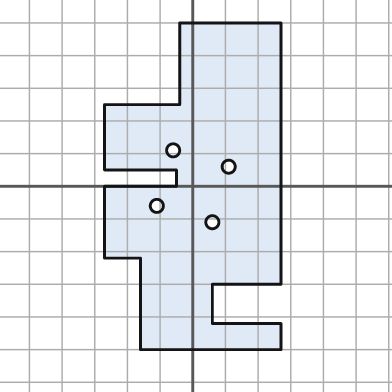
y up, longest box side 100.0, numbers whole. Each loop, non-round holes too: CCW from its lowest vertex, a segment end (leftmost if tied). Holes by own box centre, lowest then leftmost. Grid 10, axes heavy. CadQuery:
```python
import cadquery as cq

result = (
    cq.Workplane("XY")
    .moveTo(-16.0, -50.0)
    .lineTo(27.0, -50.0)
    .lineTo(27.0, -42.0)
    .lineTo(6.0, -42.0)
    .lineTo(6.0, -30.0)
    .lineTo(27.0, -30.0)
    .lineTo(27.0, 50.0)
    .lineTo(-4.0, 50.0)
    .lineTo(-4.0, 25.0)
    .lineTo(-27.0, 25.0)
    .lineTo(-27.0, 5.0)
    .lineTo(-5.0, 5.0)
    .lineTo(-5.0, 0.0)
    .lineTo(-27.0, 0.0)
    .lineTo(-27.0, -22.0)
    .lineTo(-16.0, -22.0)
    .close()
    .moveTo(6.0, -11.0)
    .circle(2.0)
    .moveTo(-11.0, -6.0)
    .circle(2.0)
    .moveTo(11.0, 6.0)
    .circle(2.0)
    .moveTo(-6.0, 11.0)
    .circle(2.0)
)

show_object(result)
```